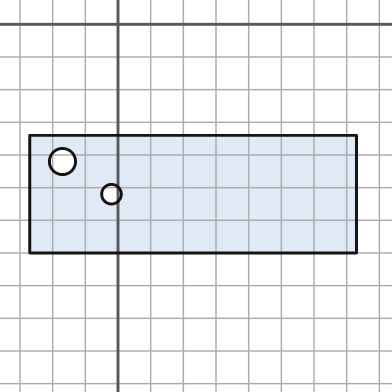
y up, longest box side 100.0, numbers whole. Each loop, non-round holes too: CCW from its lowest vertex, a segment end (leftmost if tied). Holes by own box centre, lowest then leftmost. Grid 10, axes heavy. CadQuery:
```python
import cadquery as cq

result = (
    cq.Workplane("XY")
    .moveTo(-27.0, -70.0)
    .lineTo(73.0, -70.0)
    .lineTo(73.0, -34.0)
    .lineTo(-27.0, -34.0)
    .close()
    .moveTo(-2.0, -52.0)
    .circle(3.0)
    .moveTo(-17.0, -42.0)
    .circle(4.0)
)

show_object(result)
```